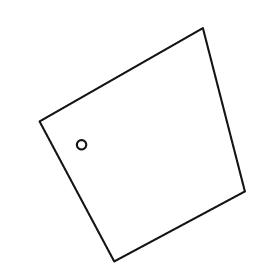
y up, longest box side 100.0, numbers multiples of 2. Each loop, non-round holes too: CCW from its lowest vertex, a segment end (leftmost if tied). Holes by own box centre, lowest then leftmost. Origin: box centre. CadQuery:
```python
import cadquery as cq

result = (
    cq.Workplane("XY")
    .moveTo(-12.0, -50.0)
    .lineTo(44.0, -20.0)
    .lineTo(26.0, 50.0)
    .lineTo(-44.0, 10.0)
    .close()
    .moveTo(-26.0, 0.0)
    .circle(2.0)
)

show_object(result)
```